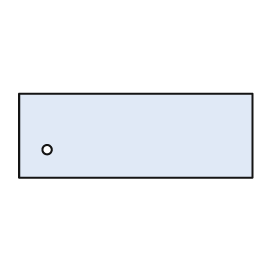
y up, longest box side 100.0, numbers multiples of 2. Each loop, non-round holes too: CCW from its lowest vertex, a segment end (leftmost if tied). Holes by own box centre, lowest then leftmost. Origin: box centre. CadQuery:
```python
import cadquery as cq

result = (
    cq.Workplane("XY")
    .moveTo(-50.0, -18.0)
    .lineTo(50.0, -18.0)
    .lineTo(50.0, 18.0)
    .lineTo(-50.0, 18.0)
    .close()
    .moveTo(-38.0, -6.0)
    .circle(2.0)
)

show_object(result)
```